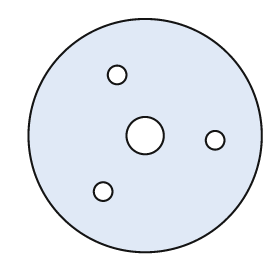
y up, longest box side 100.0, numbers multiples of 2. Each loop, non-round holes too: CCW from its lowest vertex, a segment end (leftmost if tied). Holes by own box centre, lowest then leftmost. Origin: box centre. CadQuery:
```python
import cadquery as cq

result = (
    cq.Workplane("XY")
    .moveTo(0.0, 0.0)
    .circle(50.0)
    .moveTo(-18.0, -24.0)
    .circle(4.0)
    .moveTo(30.0, -2.0)
    .circle(4.0)
    .moveTo(0.0, 0.0)
    .circle(8.0)
    .moveTo(-12.0, 26.0)
    .circle(4.0)
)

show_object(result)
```